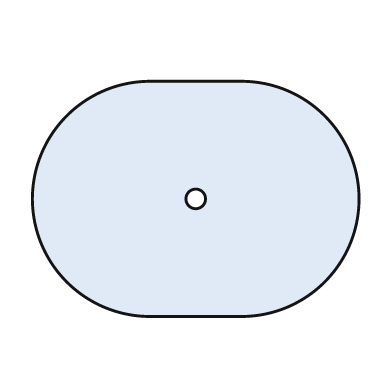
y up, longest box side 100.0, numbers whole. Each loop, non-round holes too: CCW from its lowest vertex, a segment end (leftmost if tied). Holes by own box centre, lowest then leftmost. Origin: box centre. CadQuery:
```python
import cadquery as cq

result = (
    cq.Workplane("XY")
    .moveTo(-14.0, -36.0)
    .lineTo(14.0, -36.0)
    .threePointArc((50.0, 0.0), (14.0, 36.0))
    .lineTo(-14.0, 36.0)
    .threePointArc((-50.0, 0.0), (-14.0, -36.0))
    .close()
    .moveTo(0.0, 0.0)
    .circle(3.0)
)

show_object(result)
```